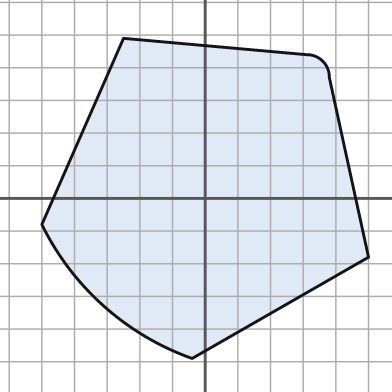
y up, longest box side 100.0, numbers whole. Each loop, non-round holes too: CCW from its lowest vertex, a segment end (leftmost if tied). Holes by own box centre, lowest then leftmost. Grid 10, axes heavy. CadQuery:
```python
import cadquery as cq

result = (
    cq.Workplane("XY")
    .moveTo(-4.0, -49.0)
    .lineTo(50.0, -18.0)
    .lineTo(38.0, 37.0)
    .threePointArc((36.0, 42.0), (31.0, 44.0))
    .lineTo(-25.0, 49.0)
    .lineTo(-50.0, -8.0)
    .threePointArc((-31.0, -33.0), (-4.0, -49.0))
    .close()
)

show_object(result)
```